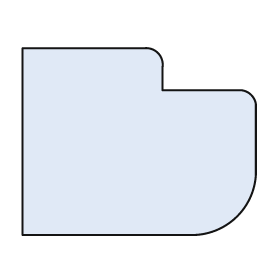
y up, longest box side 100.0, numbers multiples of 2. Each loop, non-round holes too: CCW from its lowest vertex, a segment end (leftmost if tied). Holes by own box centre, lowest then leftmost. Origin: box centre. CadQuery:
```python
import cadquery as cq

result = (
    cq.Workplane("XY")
    .moveTo(-50.0, -40.0)
    .lineTo(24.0, -40.0)
    .threePointArc((42.0, -32.0), (50.0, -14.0))
    .lineTo(50.0, 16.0)
    .threePointArc((48.0, 20.0), (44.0, 22.0))
    .lineTo(10.0, 22.0)
    .lineTo(10.0, 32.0)
    .threePointArc((8.0, 38.0), (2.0, 40.0))
    .lineTo(-50.0, 40.0)
    .close()
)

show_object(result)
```